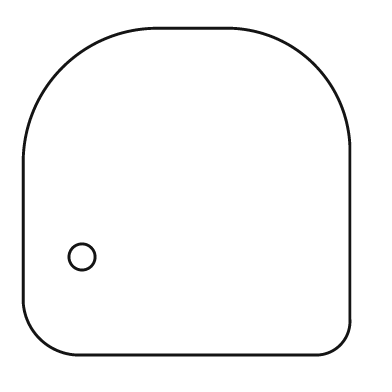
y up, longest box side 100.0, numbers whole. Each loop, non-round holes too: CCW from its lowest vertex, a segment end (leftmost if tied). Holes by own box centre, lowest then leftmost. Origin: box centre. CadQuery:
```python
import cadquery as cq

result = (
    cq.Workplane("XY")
    .moveTo(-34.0, -50.0)
    .lineTo(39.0, -50.0)
    .threePointArc((47.0, -47.0), (50.0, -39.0))
    .lineTo(50.0, 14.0)
    .threePointArc((39.0, 39.0), (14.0, 50.0))
    .lineTo(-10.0, 50.0)
    .threePointArc((-38.0, 38.0), (-50.0, 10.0))
    .lineTo(-50.0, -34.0)
    .threePointArc((-45.0, -45.0), (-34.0, -50.0))
    .close()
    .moveTo(-32.0, -20.0)
    .circle(4.0)
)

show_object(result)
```